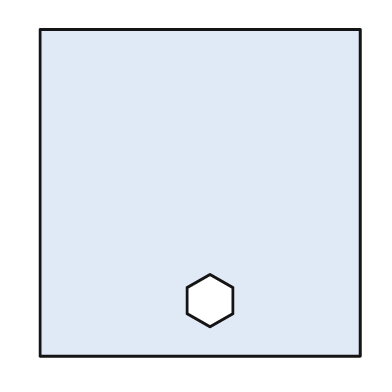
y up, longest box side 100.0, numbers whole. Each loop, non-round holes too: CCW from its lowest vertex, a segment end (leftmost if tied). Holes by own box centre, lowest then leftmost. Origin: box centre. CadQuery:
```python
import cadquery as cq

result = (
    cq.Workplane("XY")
    .moveTo(-49.0, -50.0)
    .lineTo(49.0, -50.0)
    .lineTo(49.0, 50.0)
    .lineTo(-49.0, 50.0)
    .close()
    .moveTo(3.0, -41.0)
    .lineTo(10.0, -37.0)
    .lineTo(10.0, -29.0)
    .lineTo(3.0, -25.0)
    .lineTo(-4.0, -29.0)
    .lineTo(-4.0, -37.0)
    .close()
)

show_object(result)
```